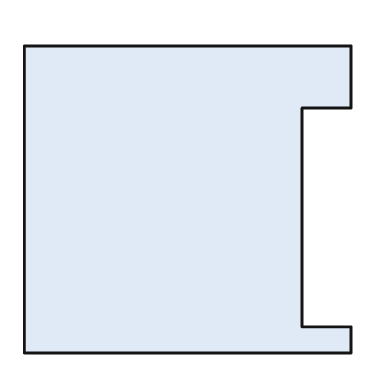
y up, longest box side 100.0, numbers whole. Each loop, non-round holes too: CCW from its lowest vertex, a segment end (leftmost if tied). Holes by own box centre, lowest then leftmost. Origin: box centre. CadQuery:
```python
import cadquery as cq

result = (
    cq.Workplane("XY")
    .moveTo(-50.0, -47.0)
    .lineTo(50.0, -47.0)
    .lineTo(50.0, -39.0)
    .lineTo(35.0, -39.0)
    .lineTo(35.0, 28.0)
    .lineTo(50.0, 28.0)
    .lineTo(50.0, 47.0)
    .lineTo(-50.0, 47.0)
    .close()
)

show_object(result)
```